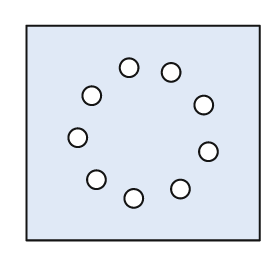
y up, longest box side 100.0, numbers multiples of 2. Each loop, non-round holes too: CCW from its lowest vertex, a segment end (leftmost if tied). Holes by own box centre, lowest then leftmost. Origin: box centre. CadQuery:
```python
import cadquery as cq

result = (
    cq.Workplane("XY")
    .moveTo(-50.0, -46.0)
    .lineTo(50.0, -46.0)
    .lineTo(50.0, 46.0)
    .lineTo(-50.0, 46.0)
    .close()
    .moveTo(-4.0, -28.0)
    .circle(4.0)
    .moveTo(16.0, -24.0)
    .circle(4.0)
    .moveTo(-20.0, -20.0)
    .circle(4.0)
    .moveTo(28.0, -8.0)
    .circle(4.0)
    .moveTo(-28.0, -2.0)
    .circle(4.0)
    .moveTo(26.0, 12.0)
    .circle(4.0)
    .moveTo(-22.0, 16.0)
    .circle(4.0)
    .moveTo(12.0, 26.0)
    .circle(4.0)
    .moveTo(-6.0, 28.0)
    .circle(4.0)
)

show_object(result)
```